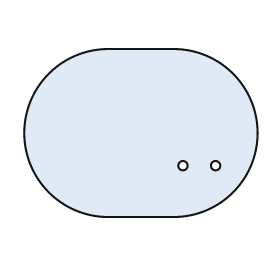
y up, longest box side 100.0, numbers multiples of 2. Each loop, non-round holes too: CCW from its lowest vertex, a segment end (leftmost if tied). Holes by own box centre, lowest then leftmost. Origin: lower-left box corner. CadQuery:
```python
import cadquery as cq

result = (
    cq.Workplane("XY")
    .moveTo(36.0, 0.0)
    .lineTo(64.0, 0.0)
    .threePointArc((100.0, 36.0), (64.0, 72.0))
    .lineTo(36.0, 72.0)
    .threePointArc((0.0, 36.0), (36.0, 0.0))
    .close()
    .moveTo(68.0, 22.0)
    .circle(2.0)
    .moveTo(82.0, 22.0)
    .circle(2.0)
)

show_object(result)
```